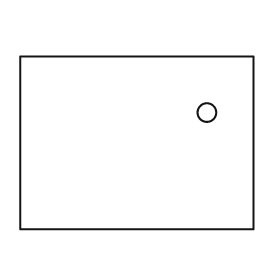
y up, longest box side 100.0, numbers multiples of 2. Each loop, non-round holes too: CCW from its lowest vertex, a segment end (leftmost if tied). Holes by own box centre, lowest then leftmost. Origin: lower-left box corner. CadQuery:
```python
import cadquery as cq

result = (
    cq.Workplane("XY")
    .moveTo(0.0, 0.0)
    .lineTo(100.0, 0.0)
    .lineTo(100.0, 74.0)
    .lineTo(0.0, 74.0)
    .close()
    .moveTo(80.0, 50.0)
    .circle(4.0)
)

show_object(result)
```